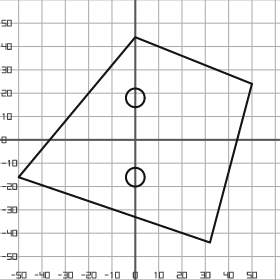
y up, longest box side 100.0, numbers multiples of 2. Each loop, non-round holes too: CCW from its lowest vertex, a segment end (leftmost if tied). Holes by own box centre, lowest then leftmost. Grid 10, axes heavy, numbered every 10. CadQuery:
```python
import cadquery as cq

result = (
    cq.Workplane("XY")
    .moveTo(32.0, -44.0)
    .lineTo(50.0, 24.0)
    .lineTo(0.0, 44.0)
    .lineTo(-50.0, -16.0)
    .close()
    .moveTo(0.0, -16.0)
    .circle(4.0)
    .moveTo(0.0, 18.0)
    .circle(4.0)
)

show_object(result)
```